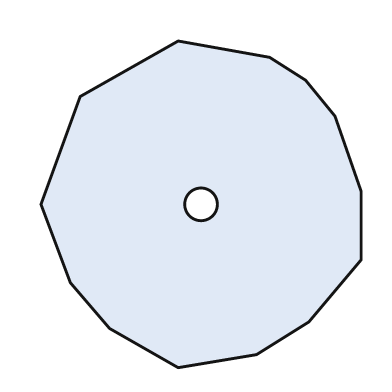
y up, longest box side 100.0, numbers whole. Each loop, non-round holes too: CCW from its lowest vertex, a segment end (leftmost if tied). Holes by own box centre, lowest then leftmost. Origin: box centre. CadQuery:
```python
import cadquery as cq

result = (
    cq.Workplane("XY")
    .moveTo(-7.0, -50.0)
    .lineTo(17.0, -46.0)
    .lineTo(33.0, -36.0)
    .lineTo(49.0, -17.0)
    .lineTo(49.0, 4.0)
    .lineTo(41.0, 27.0)
    .lineTo(32.0, 38.0)
    .lineTo(21.0, 45.0)
    .lineTo(-7.0, 50.0)
    .lineTo(-37.0, 33.0)
    .lineTo(-49.0, 0.0)
    .lineTo(-40.0, -24.0)
    .lineTo(-28.0, -38.0)
    .close()
    .moveTo(0.0, 0.0)
    .circle(5.0)
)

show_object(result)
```